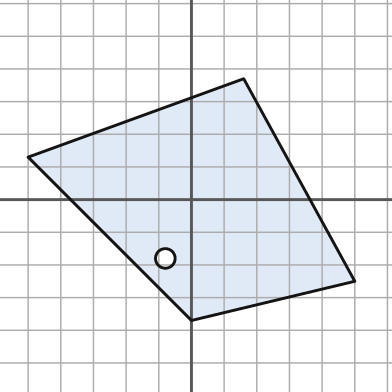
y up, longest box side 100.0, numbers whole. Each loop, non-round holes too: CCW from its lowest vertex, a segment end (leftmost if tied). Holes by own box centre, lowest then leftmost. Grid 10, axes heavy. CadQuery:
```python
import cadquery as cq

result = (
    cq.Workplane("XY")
    .moveTo(0.0, -37.0)
    .lineTo(50.0, -25.0)
    .lineTo(16.0, 37.0)
    .lineTo(-50.0, 13.0)
    .close()
    .moveTo(-8.0, -18.0)
    .circle(3.0)
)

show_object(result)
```